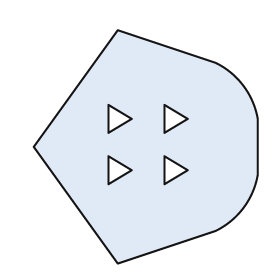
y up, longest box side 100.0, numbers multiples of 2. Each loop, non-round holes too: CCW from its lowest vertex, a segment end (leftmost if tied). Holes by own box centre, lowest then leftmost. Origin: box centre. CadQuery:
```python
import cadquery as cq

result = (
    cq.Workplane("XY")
    .moveTo(-12.0, -50.0)
    .lineTo(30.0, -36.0)
    .threePointArc((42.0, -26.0), (48.0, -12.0))
    .lineTo(48.0, 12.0)
    .threePointArc((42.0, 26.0), (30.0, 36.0))
    .lineTo(-12.0, 50.0)
    .lineTo(-48.0, 0.0)
    .close()
    .moveTo(-16.0, -16.0)
    .lineTo(-6.0, -10.0)
    .lineTo(-16.0, -4.0)
    .close()
    .moveTo(8.0, -16.0)
    .lineTo(18.0, -10.0)
    .lineTo(8.0, -4.0)
    .close()
    .moveTo(-16.0, 6.0)
    .lineTo(-6.0, 12.0)
    .lineTo(-16.0, 18.0)
    .close()
    .moveTo(8.0, 6.0)
    .lineTo(18.0, 12.0)
    .lineTo(8.0, 18.0)
    .close()
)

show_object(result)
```